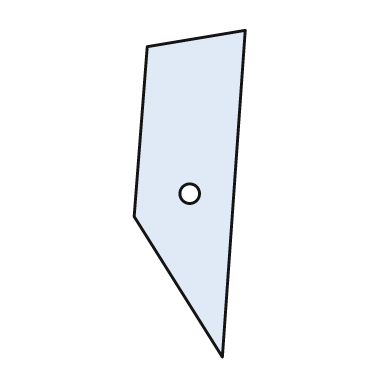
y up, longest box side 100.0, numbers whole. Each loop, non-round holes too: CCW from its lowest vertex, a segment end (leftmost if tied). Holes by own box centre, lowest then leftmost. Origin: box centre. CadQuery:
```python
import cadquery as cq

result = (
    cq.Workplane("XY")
    .moveTo(10.0, -50.0)
    .lineTo(17.0, 50.0)
    .lineTo(-13.0, 45.0)
    .lineTo(-17.0, -7.0)
    .close()
    .moveTo(0.0, 0.0)
    .circle(3.0)
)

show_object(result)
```